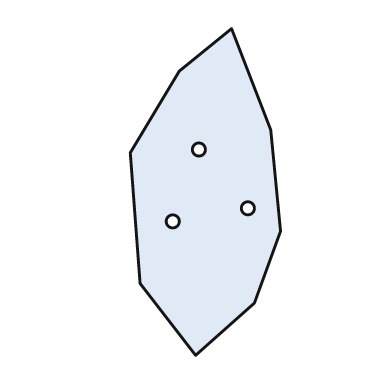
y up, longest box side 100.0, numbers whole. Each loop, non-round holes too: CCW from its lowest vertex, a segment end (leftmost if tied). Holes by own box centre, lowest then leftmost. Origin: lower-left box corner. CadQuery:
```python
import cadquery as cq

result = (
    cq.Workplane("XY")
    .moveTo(20.0, 0.0)
    .lineTo(38.0, 16.0)
    .lineTo(46.0, 38.0)
    .lineTo(43.0, 69.0)
    .lineTo(31.0, 100.0)
    .lineTo(15.0, 87.0)
    .lineTo(0.0, 62.0)
    .lineTo(3.0, 22.0)
    .close()
    .moveTo(13.0, 41.0)
    .circle(2.0)
    .moveTo(36.0, 45.0)
    .circle(2.0)
    .moveTo(21.0, 63.0)
    .circle(2.0)
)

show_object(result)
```